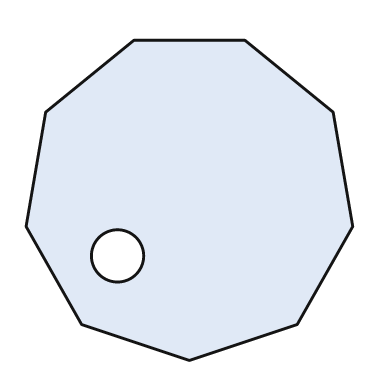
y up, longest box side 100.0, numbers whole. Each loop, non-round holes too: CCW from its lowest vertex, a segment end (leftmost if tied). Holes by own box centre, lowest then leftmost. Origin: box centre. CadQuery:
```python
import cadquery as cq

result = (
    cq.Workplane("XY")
    .moveTo(0.0, -49.0)
    .lineTo(33.0, -38.0)
    .lineTo(50.0, -8.0)
    .lineTo(44.0, 27.0)
    .lineTo(17.0, 49.0)
    .lineTo(-17.0, 49.0)
    .lineTo(-44.0, 27.0)
    .lineTo(-50.0, -8.0)
    .lineTo(-33.0, -38.0)
    .close()
    .moveTo(-22.0, -17.0)
    .circle(8.0)
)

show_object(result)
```